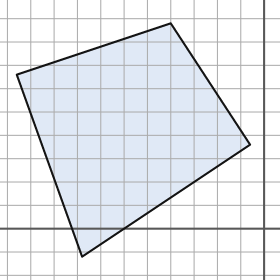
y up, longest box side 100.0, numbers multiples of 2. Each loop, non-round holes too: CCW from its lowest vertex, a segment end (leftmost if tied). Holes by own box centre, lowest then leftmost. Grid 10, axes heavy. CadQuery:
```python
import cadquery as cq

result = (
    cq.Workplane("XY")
    .moveTo(-78.0, -12.0)
    .lineTo(-6.0, 36.0)
    .lineTo(-40.0, 88.0)
    .lineTo(-106.0, 66.0)
    .close()
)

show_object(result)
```